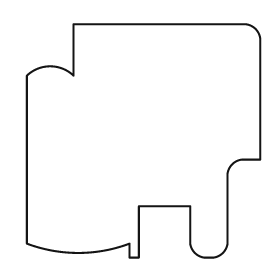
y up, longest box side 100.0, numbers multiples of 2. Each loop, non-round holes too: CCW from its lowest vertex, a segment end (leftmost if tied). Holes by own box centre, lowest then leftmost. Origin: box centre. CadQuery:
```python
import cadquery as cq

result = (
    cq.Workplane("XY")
    .moveTo(-6.0, -50.0)
    .lineTo(-2.0, -50.0)
    .lineTo(-2.0, -28.0)
    .lineTo(20.0, -28.0)
    .lineTo(20.0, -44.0)
    .threePointArc((22.0, -48.0), (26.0, -50.0))
    .lineTo(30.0, -50.0)
    .threePointArc((34.0, -48.0), (36.0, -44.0))
    .lineTo(36.0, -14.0)
    .threePointArc((38.0, -10.0), (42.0, -8.0))
    .lineTo(50.0, -8.0)
    .lineTo(50.0, 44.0)
    .threePointArc((48.0, 48.0), (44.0, 50.0))
    .lineTo(-30.0, 50.0)
    .lineTo(-30.0, 28.0)
    .threePointArc((-40.0, 32.0), (-50.0, 28.0))
    .lineTo(-50.0, -44.0)
    .threePointArc((-28.0, -48.0), (-6.0, -44.0))
    .close()
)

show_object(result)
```